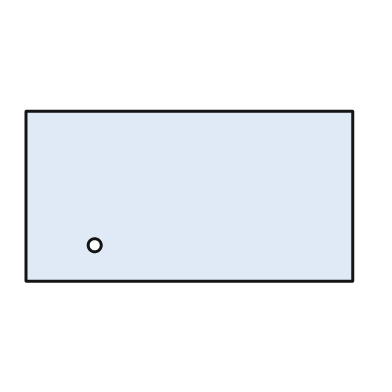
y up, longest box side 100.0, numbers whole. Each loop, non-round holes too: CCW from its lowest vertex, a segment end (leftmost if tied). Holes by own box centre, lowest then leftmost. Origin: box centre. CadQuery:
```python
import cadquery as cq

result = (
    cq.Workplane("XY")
    .moveTo(-50.0, -26.0)
    .lineTo(50.0, -26.0)
    .lineTo(50.0, 26.0)
    .lineTo(-50.0, 26.0)
    .close()
    .moveTo(-29.0, -15.0)
    .circle(2.0)
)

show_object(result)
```